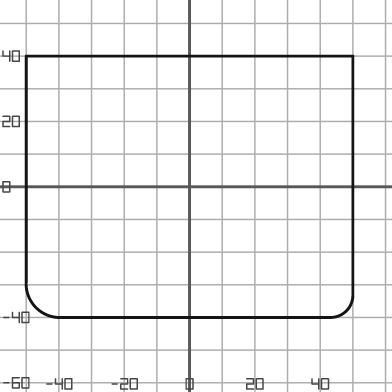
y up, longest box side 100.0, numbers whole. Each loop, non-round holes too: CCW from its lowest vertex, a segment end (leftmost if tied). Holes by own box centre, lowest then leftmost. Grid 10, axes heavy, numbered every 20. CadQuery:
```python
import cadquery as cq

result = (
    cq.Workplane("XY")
    .moveTo(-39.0, -40.0)
    .lineTo(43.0, -40.0)
    .threePointArc((48.0, -38.0), (50.0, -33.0))
    .lineTo(50.0, 40.0)
    .lineTo(-50.0, 40.0)
    .lineTo(-50.0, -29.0)
    .threePointArc((-47.0, -37.0), (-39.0, -40.0))
    .close()
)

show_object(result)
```